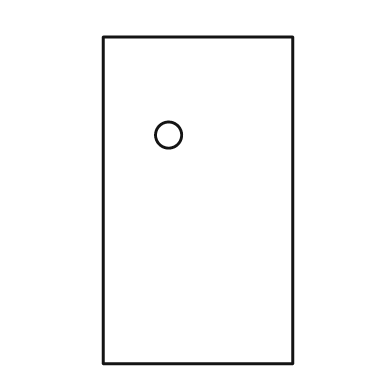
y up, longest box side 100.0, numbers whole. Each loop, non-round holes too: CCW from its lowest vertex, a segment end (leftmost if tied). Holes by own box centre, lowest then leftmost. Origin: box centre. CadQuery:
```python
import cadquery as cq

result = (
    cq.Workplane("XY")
    .moveTo(-29.0, -50.0)
    .lineTo(29.0, -50.0)
    .lineTo(29.0, 50.0)
    .lineTo(-29.0, 50.0)
    .close()
    .moveTo(-9.0, 20.0)
    .circle(4.0)
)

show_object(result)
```